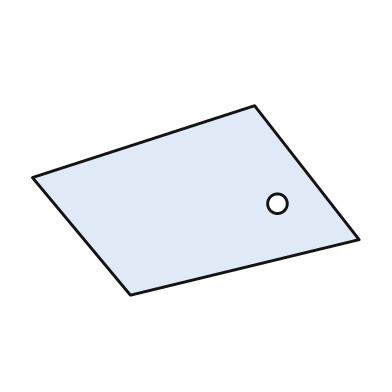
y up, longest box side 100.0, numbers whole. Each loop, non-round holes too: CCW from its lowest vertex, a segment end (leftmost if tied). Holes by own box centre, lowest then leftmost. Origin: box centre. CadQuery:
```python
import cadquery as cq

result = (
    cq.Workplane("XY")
    .moveTo(-20.0, -29.0)
    .lineTo(50.0, -12.0)
    .lineTo(18.0, 29.0)
    .lineTo(-50.0, 7.0)
    .close()
    .moveTo(25.0, -1.0)
    .circle(3.0)
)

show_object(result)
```